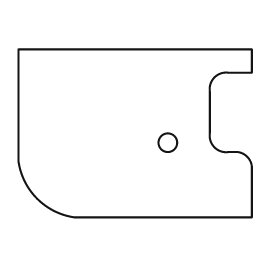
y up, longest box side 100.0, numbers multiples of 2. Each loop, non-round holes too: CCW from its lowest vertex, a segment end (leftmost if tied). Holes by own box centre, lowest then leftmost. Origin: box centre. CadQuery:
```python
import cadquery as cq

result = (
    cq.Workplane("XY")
    .moveTo(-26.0, -36.0)
    .lineTo(50.0, -36.0)
    .lineTo(50.0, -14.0)
    .threePointArc((48.0, -10.0), (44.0, -8.0))
    .lineTo(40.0, -8.0)
    .threePointArc((34.0, -6.0), (32.0, 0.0))
    .lineTo(32.0, 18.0)
    .threePointArc((34.0, 24.0), (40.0, 26.0))
    .lineTo(50.0, 26.0)
    .lineTo(50.0, 36.0)
    .lineTo(-50.0, 36.0)
    .lineTo(-50.0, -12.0)
    .threePointArc((-42.0, -28.0), (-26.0, -36.0))
    .close()
    .moveTo(14.0, -4.0)
    .circle(4.0)
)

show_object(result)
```